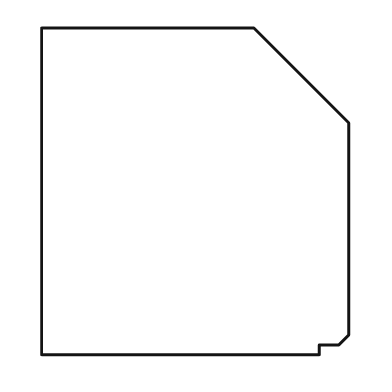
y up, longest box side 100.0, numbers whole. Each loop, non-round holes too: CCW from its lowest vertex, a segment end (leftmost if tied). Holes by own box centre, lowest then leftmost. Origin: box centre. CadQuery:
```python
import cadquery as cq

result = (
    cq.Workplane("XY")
    .moveTo(-47.0, -50.0)
    .lineTo(38.0, -50.0)
    .lineTo(38.0, -47.0)
    .lineTo(44.0, -47.0)
    .lineTo(47.0, -44.0)
    .lineTo(47.0, 21.0)
    .lineTo(18.0, 50.0)
    .lineTo(-47.0, 50.0)
    .close()
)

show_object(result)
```